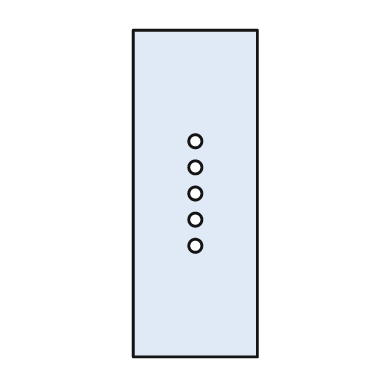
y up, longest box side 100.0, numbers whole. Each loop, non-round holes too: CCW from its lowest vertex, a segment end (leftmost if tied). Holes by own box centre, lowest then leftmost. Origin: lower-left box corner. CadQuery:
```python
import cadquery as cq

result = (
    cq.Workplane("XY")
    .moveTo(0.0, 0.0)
    .lineTo(38.0, 0.0)
    .lineTo(38.0, 100.0)
    .lineTo(0.0, 100.0)
    .close()
    .moveTo(19.0, 34.0)
    .circle(2.0)
    .moveTo(19.0, 42.0)
    .circle(2.0)
    .moveTo(19.0, 50.0)
    .circle(2.0)
    .moveTo(19.0, 58.0)
    .circle(2.0)
    .moveTo(19.0, 66.0)
    .circle(2.0)
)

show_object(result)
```